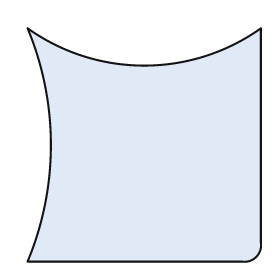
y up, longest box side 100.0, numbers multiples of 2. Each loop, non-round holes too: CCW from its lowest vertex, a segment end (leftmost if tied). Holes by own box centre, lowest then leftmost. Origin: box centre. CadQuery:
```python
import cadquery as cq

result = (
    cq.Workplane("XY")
    .moveTo(-50.0, -50.0)
    .lineTo(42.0, -50.0)
    .threePointArc((48.0, -48.0), (50.0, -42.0))
    .lineTo(50.0, 50.0)
    .threePointArc((0.0, 34.0), (-50.0, 50.0))
    .threePointArc((-40.0, 0.0), (-50.0, -50.0))
    .close()
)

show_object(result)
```